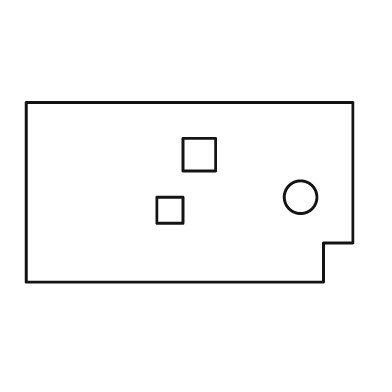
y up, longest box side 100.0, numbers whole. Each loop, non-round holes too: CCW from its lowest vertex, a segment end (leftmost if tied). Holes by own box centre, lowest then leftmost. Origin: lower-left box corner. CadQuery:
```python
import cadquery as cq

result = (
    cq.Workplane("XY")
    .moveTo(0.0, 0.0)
    .lineTo(91.0, 0.0)
    .lineTo(91.0, 12.0)
    .lineTo(100.0, 12.0)
    .lineTo(100.0, 55.0)
    .lineTo(0.0, 55.0)
    .close()
    .moveTo(40.0, 18.0)
    .lineTo(48.0, 18.0)
    .lineTo(48.0, 26.0)
    .lineTo(40.0, 26.0)
    .close()
    .moveTo(84.0, 26.0)
    .circle(5.0)
    .moveTo(48.0, 34.0)
    .lineTo(58.0, 34.0)
    .lineTo(58.0, 44.0)
    .lineTo(48.0, 44.0)
    .close()
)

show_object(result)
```